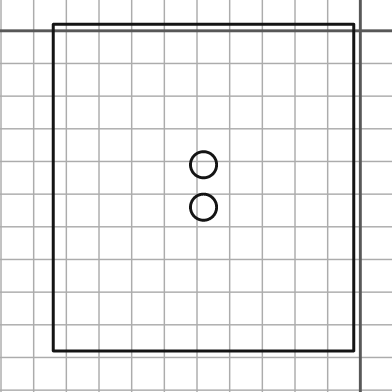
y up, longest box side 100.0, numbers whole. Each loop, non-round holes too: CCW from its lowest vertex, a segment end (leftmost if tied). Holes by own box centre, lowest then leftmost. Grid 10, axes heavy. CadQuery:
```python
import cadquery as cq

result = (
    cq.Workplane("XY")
    .moveTo(-94.0, -98.0)
    .lineTo(-2.0, -98.0)
    .lineTo(-2.0, 2.0)
    .lineTo(-94.0, 2.0)
    .close()
    .moveTo(-48.0, -54.0)
    .circle(4.0)
    .moveTo(-48.0, -41.0)
    .circle(4.0)
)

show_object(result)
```